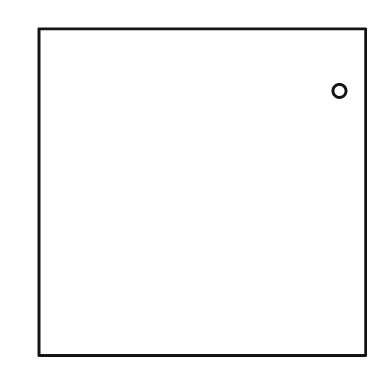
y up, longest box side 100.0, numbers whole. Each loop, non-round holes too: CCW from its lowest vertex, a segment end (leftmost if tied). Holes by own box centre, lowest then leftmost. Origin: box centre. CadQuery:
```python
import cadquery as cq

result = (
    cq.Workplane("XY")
    .moveTo(-50.0, -50.0)
    .lineTo(50.0, -50.0)
    .lineTo(50.0, 50.0)
    .lineTo(-50.0, 50.0)
    .close()
    .moveTo(42.0, 31.0)
    .circle(2.0)
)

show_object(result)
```